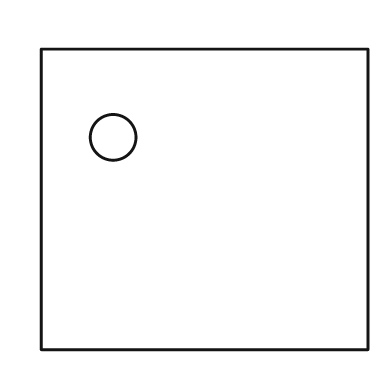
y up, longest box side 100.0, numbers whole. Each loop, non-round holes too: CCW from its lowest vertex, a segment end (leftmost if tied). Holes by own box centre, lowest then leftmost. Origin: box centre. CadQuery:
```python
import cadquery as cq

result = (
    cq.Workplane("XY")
    .moveTo(-50.0, -46.0)
    .lineTo(50.0, -46.0)
    .lineTo(50.0, 46.0)
    .lineTo(-50.0, 46.0)
    .close()
    .moveTo(-28.0, 19.0)
    .circle(7.0)
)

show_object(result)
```